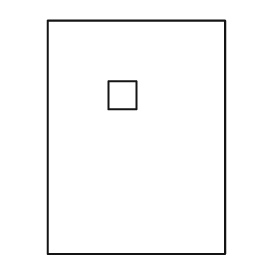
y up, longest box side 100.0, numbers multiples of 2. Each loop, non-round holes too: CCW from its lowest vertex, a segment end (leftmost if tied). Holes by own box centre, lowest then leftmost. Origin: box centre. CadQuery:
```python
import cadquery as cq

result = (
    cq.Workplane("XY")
    .moveTo(-38.0, -50.0)
    .lineTo(38.0, -50.0)
    .lineTo(38.0, 50.0)
    .lineTo(-38.0, 50.0)
    .close()
    .moveTo(-12.0, 12.0)
    .lineTo(0.0, 12.0)
    .lineTo(0.0, 24.0)
    .lineTo(-12.0, 24.0)
    .close()
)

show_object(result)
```